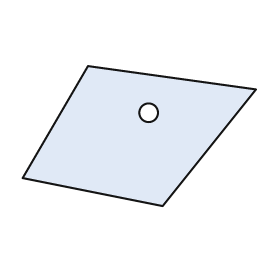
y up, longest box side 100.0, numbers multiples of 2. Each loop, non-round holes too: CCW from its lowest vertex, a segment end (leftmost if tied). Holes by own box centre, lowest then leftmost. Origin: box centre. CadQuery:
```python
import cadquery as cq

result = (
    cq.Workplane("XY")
    .moveTo(10.0, -30.0)
    .lineTo(50.0, 20.0)
    .lineTo(-22.0, 30.0)
    .lineTo(-50.0, -18.0)
    .close()
    .moveTo(4.0, 10.0)
    .circle(4.0)
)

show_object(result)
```